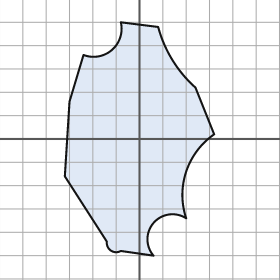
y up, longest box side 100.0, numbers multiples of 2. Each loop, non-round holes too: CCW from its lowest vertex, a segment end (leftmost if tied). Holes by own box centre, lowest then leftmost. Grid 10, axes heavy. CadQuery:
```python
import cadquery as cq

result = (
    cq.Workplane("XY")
    .moveTo(6.0, -50.0)
    .threePointArc((6.0, -36.0), (20.0, -34.0))
    .threePointArc((20.0, -14.0), (32.0, 2.0))
    .lineTo(24.0, 22.0)
    .threePointArc((14.0, 34.0), (8.0, 48.0))
    .lineTo(-8.0, 50.0)
    .threePointArc((-12.0, 38.0), (-24.0, 36.0))
    .lineTo(-30.0, 16.0)
    .lineTo(-32.0, -16.0)
    .lineTo(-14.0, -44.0)
    .threePointArc((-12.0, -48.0), (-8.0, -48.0))
    .close()
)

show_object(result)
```